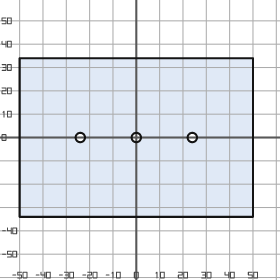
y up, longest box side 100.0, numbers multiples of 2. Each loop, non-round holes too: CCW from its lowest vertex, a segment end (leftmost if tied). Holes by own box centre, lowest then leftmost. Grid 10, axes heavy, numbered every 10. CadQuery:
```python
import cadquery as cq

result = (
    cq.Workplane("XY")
    .moveTo(-50.0, -34.0)
    .lineTo(50.0, -34.0)
    .lineTo(50.0, 34.0)
    .lineTo(-50.0, 34.0)
    .close()
    .moveTo(-24.0, 0.0)
    .circle(2.0)
    .moveTo(0.0, 0.0)
    .circle(2.0)
    .moveTo(24.0, 0.0)
    .circle(2.0)
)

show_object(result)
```